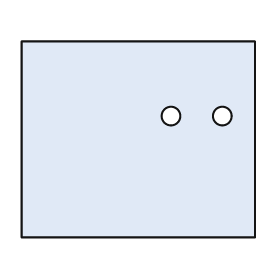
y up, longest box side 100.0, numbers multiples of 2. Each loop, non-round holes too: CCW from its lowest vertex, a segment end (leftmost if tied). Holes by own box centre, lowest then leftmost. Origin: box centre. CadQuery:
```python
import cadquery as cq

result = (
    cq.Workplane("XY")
    .moveTo(-50.0, -42.0)
    .lineTo(50.0, -42.0)
    .lineTo(50.0, 42.0)
    .lineTo(-50.0, 42.0)
    .close()
    .moveTo(14.0, 10.0)
    .circle(4.0)
    .moveTo(36.0, 10.0)
    .circle(4.0)
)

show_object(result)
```